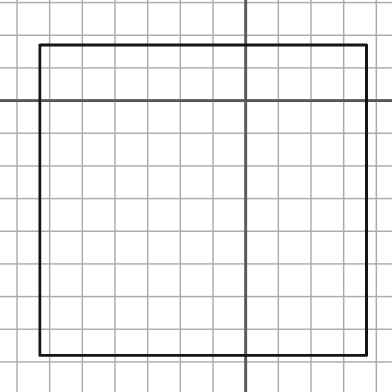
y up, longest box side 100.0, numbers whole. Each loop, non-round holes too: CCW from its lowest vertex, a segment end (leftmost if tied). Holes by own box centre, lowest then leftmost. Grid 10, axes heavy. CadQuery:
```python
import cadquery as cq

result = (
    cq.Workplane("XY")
    .moveTo(-63.0, -78.0)
    .lineTo(37.0, -78.0)
    .lineTo(37.0, 17.0)
    .lineTo(-63.0, 17.0)
    .close()
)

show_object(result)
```